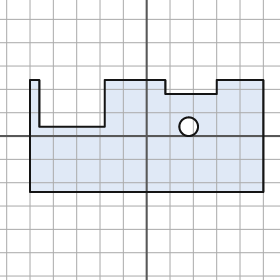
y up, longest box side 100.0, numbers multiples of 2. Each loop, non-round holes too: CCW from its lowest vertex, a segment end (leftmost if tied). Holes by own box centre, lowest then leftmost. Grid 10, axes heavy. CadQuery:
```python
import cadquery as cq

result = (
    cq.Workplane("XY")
    .moveTo(-50.0, -24.0)
    .lineTo(50.0, -24.0)
    .lineTo(50.0, 24.0)
    .lineTo(30.0, 24.0)
    .lineTo(30.0, 18.0)
    .lineTo(8.0, 18.0)
    .lineTo(8.0, 24.0)
    .lineTo(-18.0, 24.0)
    .lineTo(-18.0, 4.0)
    .lineTo(-46.0, 4.0)
    .lineTo(-46.0, 24.0)
    .lineTo(-50.0, 24.0)
    .close()
    .moveTo(18.0, 4.0)
    .circle(4.0)
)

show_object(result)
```